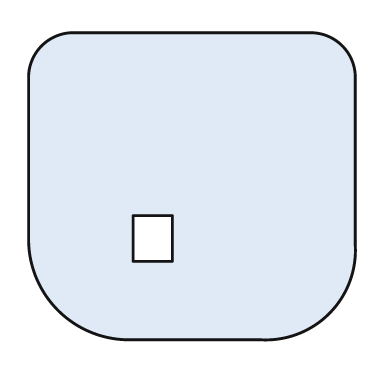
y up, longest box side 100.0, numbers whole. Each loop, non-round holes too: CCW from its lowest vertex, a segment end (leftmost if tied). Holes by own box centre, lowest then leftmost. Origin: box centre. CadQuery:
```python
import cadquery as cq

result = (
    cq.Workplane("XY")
    .moveTo(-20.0, -47.0)
    .lineTo(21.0, -47.0)
    .threePointArc((42.0, -39.0), (50.0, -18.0))
    .lineTo(50.0, 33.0)
    .threePointArc((46.0, 43.0), (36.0, 47.0))
    .lineTo(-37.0, 47.0)
    .threePointArc((-46.0, 43.0), (-50.0, 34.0))
    .lineTo(-50.0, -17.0)
    .threePointArc((-41.0, -38.0), (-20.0, -47.0))
    .close()
    .moveTo(-18.0, -23.0)
    .lineTo(-6.0, -23.0)
    .lineTo(-6.0, -9.0)
    .lineTo(-18.0, -9.0)
    .close()
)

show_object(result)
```